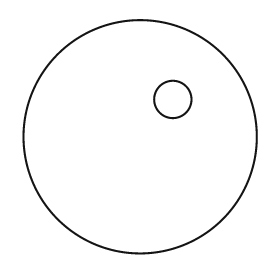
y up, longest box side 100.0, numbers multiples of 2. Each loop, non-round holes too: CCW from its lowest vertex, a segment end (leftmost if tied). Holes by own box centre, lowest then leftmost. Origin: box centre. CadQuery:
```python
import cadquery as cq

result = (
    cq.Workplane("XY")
    .moveTo(0.0, 0.0)
    .circle(50.0)
    .moveTo(14.0, 16.0)
    .circle(8.0)
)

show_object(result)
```